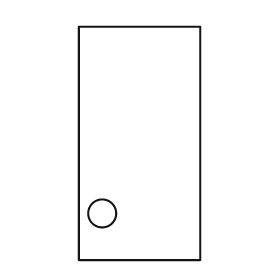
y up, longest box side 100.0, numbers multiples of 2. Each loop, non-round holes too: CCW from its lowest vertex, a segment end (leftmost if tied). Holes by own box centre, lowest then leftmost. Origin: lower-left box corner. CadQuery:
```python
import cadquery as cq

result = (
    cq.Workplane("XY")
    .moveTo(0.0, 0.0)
    .lineTo(52.0, 0.0)
    .lineTo(52.0, 100.0)
    .lineTo(0.0, 100.0)
    .close()
    .moveTo(10.0, 20.0)
    .circle(6.0)
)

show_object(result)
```